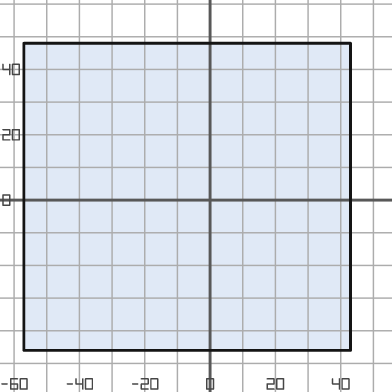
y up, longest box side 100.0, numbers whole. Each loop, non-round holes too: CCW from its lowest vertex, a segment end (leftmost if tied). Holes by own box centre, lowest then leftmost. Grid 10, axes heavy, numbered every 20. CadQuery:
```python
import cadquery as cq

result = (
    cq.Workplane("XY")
    .moveTo(-57.0, -46.0)
    .lineTo(43.0, -46.0)
    .lineTo(43.0, 48.0)
    .lineTo(-57.0, 48.0)
    .close()
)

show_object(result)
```